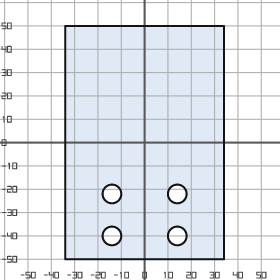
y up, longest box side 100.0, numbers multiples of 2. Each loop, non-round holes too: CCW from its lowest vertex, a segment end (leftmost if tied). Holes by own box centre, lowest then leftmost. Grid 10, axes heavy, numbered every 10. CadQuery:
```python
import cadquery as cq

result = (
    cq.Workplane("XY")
    .moveTo(-34.0, -50.0)
    .lineTo(34.0, -50.0)
    .lineTo(34.0, 50.0)
    .lineTo(-34.0, 50.0)
    .close()
    .moveTo(-14.0, -40.0)
    .circle(4.0)
    .moveTo(14.0, -40.0)
    .circle(4.0)
    .moveTo(-14.0, -22.0)
    .circle(4.0)
    .moveTo(14.0, -22.0)
    .circle(4.0)
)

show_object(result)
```